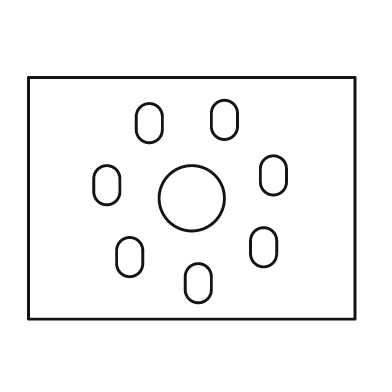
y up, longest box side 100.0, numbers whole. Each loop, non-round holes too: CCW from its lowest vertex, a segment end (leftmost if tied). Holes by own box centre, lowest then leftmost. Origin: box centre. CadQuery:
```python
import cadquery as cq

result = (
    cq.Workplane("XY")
    .moveTo(-50.0, -37.0)
    .lineTo(50.0, -37.0)
    .lineTo(50.0, 37.0)
    .lineTo(-50.0, 37.0)
    .close()
    .moveTo(-2.0, -28.0)
    .threePointArc((2.0, -32.0), (6.0, -28.0))
    .lineTo(6.0, -24.0)
    .threePointArc((2.0, -20.0), (-2.0, -24.0))
    .close()
    .moveTo(-23.0, -20.0)
    .threePointArc((-19.0, -24.0), (-15.0, -20.0))
    .lineTo(-15.0, -16.0)
    .threePointArc((-19.0, -12.0), (-23.0, -16.0))
    .close()
    .moveTo(18.0, -17.0)
    .threePointArc((22.0, -21.0), (26.0, -17.0))
    .lineTo(26.0, -13.0)
    .threePointArc((22.0, -9.0), (18.0, -13.0))
    .close()
    .moveTo(0.0, 0.0)
    .circle(10.0)
    .moveTo(-30.0, 2.0)
    .threePointArc((-26.0, -2.0), (-22.0, 2.0))
    .lineTo(-22.0, 6.0)
    .threePointArc((-26.0, 10.0), (-30.0, 6.0))
    .close()
    .moveTo(21.0, 5.0)
    .threePointArc((25.0, 1.0), (29.0, 5.0))
    .lineTo(29.0, 9.0)
    .threePointArc((25.0, 13.0), (21.0, 9.0))
    .close()
    .moveTo(-17.0, 21.0)
    .threePointArc((-13.0, 17.0), (-9.0, 21.0))
    .lineTo(-9.0, 25.0)
    .threePointArc((-13.0, 29.0), (-17.0, 25.0))
    .close()
    .moveTo(6.0, 22.0)
    .threePointArc((10.0, 18.0), (14.0, 22.0))
    .lineTo(14.0, 26.0)
    .threePointArc((10.0, 30.0), (6.0, 26.0))
    .close()
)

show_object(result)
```